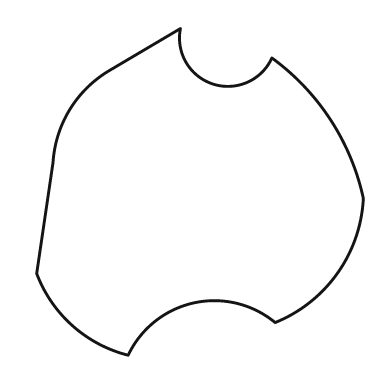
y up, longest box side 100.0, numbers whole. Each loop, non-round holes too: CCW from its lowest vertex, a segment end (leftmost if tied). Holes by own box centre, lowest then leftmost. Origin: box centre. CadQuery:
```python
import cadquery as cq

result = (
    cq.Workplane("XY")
    .moveTo(-22.0, -50.0)
    .threePointArc((-2.0, -34.0), (23.0, -40.0))
    .threePointArc((42.0, -25.0), (50.0, -2.0))
    .threePointArc((40.0, 22.0), (22.0, 41.0))
    .threePointArc((4.0, 33.0), (-6.0, 50.0))
    .lineTo(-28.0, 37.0)
    .threePointArc((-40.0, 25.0), (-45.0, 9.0))
    .lineTo(-50.0, -25.0)
    .threePointArc((-39.0, -41.0), (-22.0, -50.0))
    .close()
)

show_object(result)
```